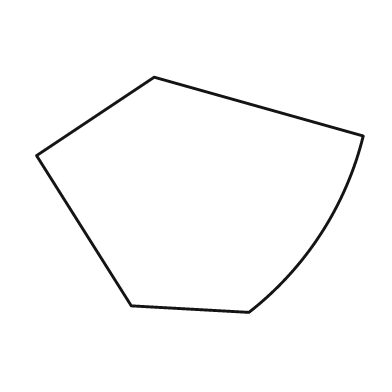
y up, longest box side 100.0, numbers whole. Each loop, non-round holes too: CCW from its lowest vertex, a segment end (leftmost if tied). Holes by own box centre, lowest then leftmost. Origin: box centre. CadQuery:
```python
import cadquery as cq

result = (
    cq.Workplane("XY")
    .moveTo(15.0, -36.0)
    .threePointArc((37.0, -12.0), (50.0, 18.0))
    .lineTo(-14.0, 36.0)
    .lineTo(-50.0, 12.0)
    .lineTo(-21.0, -34.0)
    .close()
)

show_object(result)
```